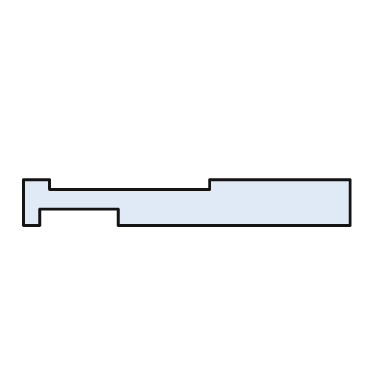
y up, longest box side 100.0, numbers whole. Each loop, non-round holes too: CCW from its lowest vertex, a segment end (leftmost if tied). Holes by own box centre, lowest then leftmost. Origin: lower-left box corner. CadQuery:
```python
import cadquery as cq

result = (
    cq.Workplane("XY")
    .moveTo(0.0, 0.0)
    .lineTo(5.0, 0.0)
    .lineTo(5.0, 5.0)
    .lineTo(29.0, 5.0)
    .lineTo(29.0, 0.0)
    .lineTo(100.0, 0.0)
    .lineTo(100.0, 14.0)
    .lineTo(57.0, 14.0)
    .lineTo(57.0, 11.0)
    .lineTo(8.0, 11.0)
    .lineTo(8.0, 14.0)
    .lineTo(0.0, 14.0)
    .close()
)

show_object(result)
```